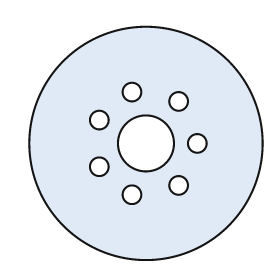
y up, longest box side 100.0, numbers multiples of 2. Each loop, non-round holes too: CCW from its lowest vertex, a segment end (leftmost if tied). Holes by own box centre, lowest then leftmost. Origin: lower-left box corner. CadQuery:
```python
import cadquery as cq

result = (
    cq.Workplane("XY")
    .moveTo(50.0, 50.0)
    .circle(50.0)
    .moveTo(44.0, 28.0)
    .circle(4.0)
    .moveTo(64.0, 32.0)
    .circle(4.0)
    .moveTo(30.0, 40.0)
    .circle(4.0)
    .moveTo(50.0, 50.0)
    .circle(12.0)
    .moveTo(72.0, 50.0)
    .circle(4.0)
    .moveTo(30.0, 60.0)
    .circle(4.0)
    .moveTo(64.0, 68.0)
    .circle(4.0)
    .moveTo(44.0, 72.0)
    .circle(4.0)
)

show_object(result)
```